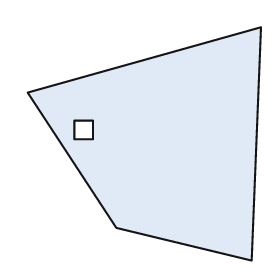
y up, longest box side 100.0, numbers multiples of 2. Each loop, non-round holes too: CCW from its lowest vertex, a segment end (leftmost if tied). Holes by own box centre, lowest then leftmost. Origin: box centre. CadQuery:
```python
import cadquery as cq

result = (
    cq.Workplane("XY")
    .moveTo(46.0, -50.0)
    .lineTo(50.0, 50.0)
    .lineTo(-50.0, 22.0)
    .lineTo(-12.0, -36.0)
    .close()
    .moveTo(-30.0, 2.0)
    .lineTo(-22.0, 2.0)
    .lineTo(-22.0, 10.0)
    .lineTo(-30.0, 10.0)
    .close()
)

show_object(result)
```